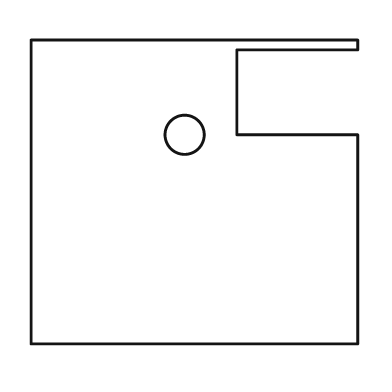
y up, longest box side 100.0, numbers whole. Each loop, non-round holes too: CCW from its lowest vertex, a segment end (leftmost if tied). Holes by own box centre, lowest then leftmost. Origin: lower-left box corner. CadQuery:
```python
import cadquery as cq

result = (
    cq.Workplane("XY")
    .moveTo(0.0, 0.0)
    .lineTo(100.0, 0.0)
    .lineTo(100.0, 64.0)
    .lineTo(63.0, 64.0)
    .lineTo(63.0, 90.0)
    .lineTo(100.0, 90.0)
    .lineTo(100.0, 93.0)
    .lineTo(0.0, 93.0)
    .close()
    .moveTo(47.0, 64.0)
    .circle(6.0)
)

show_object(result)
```